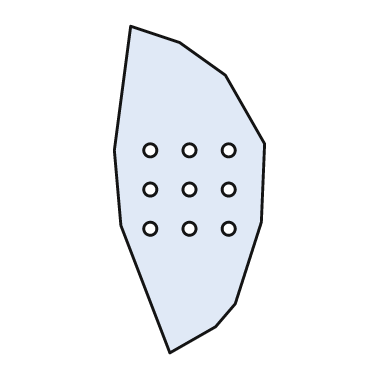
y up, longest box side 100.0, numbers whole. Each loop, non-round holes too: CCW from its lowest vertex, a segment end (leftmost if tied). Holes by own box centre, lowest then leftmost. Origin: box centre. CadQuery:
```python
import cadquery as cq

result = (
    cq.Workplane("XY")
    .moveTo(-6.0, -50.0)
    .lineTo(8.0, -42.0)
    .lineTo(14.0, -35.0)
    .lineTo(22.0, -10.0)
    .lineTo(23.0, 14.0)
    .lineTo(11.0, 35.0)
    .lineTo(-3.0, 45.0)
    .lineTo(-18.0, 50.0)
    .lineTo(-23.0, 12.0)
    .lineTo(-21.0, -11.0)
    .close()
    .moveTo(-12.0, -12.0)
    .circle(2.0)
    .moveTo(0.0, -12.0)
    .circle(2.0)
    .moveTo(12.0, -12.0)
    .circle(2.0)
    .moveTo(-12.0, 0.0)
    .circle(2.0)
    .moveTo(0.0, 0.0)
    .circle(2.0)
    .moveTo(12.0, 0.0)
    .circle(2.0)
    .moveTo(-12.0, 12.0)
    .circle(2.0)
    .moveTo(0.0, 12.0)
    .circle(2.0)
    .moveTo(12.0, 12.0)
    .circle(2.0)
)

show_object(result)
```